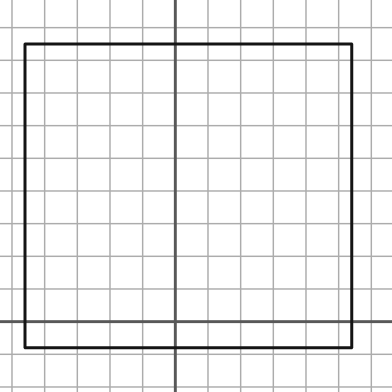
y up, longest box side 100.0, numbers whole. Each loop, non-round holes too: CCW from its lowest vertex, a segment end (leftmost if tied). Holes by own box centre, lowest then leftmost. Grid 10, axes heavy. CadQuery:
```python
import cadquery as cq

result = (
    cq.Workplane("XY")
    .moveTo(-46.0, -8.0)
    .lineTo(54.0, -8.0)
    .lineTo(54.0, 85.0)
    .lineTo(-46.0, 85.0)
    .close()
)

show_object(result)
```